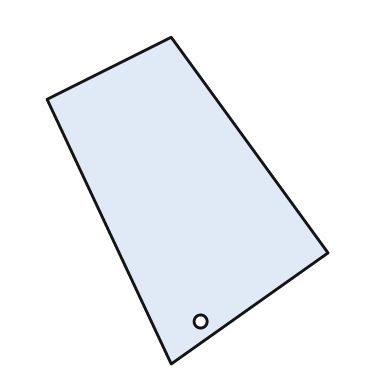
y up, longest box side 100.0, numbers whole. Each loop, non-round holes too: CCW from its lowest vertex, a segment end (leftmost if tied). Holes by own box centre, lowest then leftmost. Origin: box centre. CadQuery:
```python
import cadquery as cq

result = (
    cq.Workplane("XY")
    .moveTo(-5.0, -50.0)
    .lineTo(43.0, -16.0)
    .lineTo(-5.0, 50.0)
    .lineTo(-43.0, 31.0)
    .close()
    .moveTo(4.0, -37.0)
    .circle(2.0)
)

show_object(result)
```